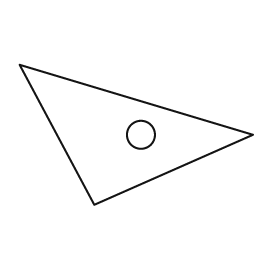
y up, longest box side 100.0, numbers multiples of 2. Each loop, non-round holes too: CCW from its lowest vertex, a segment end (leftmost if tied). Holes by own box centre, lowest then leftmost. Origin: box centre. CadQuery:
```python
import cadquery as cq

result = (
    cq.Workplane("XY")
    .moveTo(-18.0, -30.0)
    .lineTo(50.0, 0.0)
    .lineTo(-50.0, 30.0)
    .close()
    .moveTo(2.0, 0.0)
    .circle(6.0)
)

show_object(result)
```